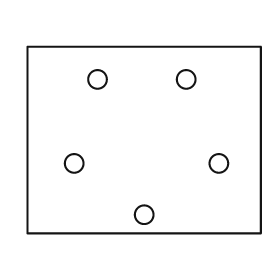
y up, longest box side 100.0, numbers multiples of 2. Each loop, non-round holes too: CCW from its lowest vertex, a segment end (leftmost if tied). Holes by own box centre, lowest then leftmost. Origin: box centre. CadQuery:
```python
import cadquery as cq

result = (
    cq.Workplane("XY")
    .moveTo(-50.0, -40.0)
    .lineTo(50.0, -40.0)
    .lineTo(50.0, 40.0)
    .lineTo(-50.0, 40.0)
    .close()
    .moveTo(0.0, -32.0)
    .circle(4.0)
    .moveTo(-30.0, -10.0)
    .circle(4.0)
    .moveTo(32.0, -10.0)
    .circle(4.0)
    .moveTo(-20.0, 26.0)
    .circle(4.0)
    .moveTo(18.0, 26.0)
    .circle(4.0)
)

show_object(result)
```